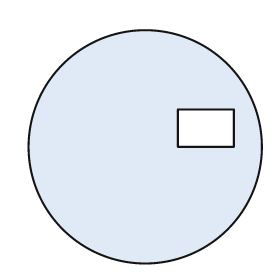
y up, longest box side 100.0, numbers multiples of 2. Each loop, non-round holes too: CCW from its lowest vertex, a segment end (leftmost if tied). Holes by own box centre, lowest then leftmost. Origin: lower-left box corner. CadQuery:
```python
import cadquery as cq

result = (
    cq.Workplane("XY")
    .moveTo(50.0, 50.0)
    .circle(50.0)
    .moveTo(64.0, 50.0)
    .lineTo(88.0, 50.0)
    .lineTo(88.0, 66.0)
    .lineTo(64.0, 66.0)
    .close()
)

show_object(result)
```